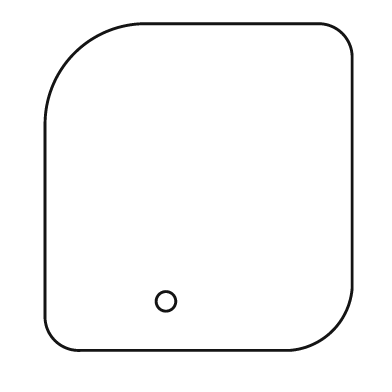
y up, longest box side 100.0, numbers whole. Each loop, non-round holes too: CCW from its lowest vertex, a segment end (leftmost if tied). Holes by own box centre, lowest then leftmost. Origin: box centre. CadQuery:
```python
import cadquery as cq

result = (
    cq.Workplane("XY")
    .moveTo(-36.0, -50.0)
    .lineTo(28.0, -50.0)
    .threePointArc((41.0, -44.0), (47.0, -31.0))
    .lineTo(47.0, 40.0)
    .threePointArc((44.0, 47.0), (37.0, 50.0))
    .lineTo(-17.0, 50.0)
    .threePointArc((-38.0, 41.0), (-47.0, 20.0))
    .lineTo(-47.0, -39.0)
    .threePointArc((-44.0, -47.0), (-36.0, -50.0))
    .close()
    .moveTo(-10.0, -35.0)
    .circle(3.0)
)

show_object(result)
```